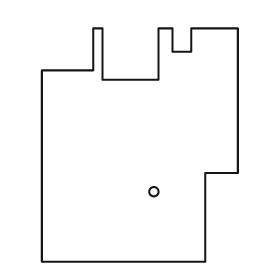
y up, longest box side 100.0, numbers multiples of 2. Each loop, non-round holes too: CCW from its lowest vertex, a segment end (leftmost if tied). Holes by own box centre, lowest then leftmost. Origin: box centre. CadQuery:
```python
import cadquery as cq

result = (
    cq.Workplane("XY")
    .moveTo(-42.0, -50.0)
    .lineTo(28.0, -50.0)
    .lineTo(28.0, -12.0)
    .lineTo(42.0, -12.0)
    .lineTo(42.0, 50.0)
    .lineTo(22.0, 50.0)
    .lineTo(22.0, 40.0)
    .lineTo(14.0, 40.0)
    .lineTo(14.0, 50.0)
    .lineTo(8.0, 50.0)
    .lineTo(8.0, 28.0)
    .lineTo(-16.0, 28.0)
    .lineTo(-16.0, 50.0)
    .lineTo(-20.0, 50.0)
    .lineTo(-20.0, 32.0)
    .lineTo(-42.0, 32.0)
    .close()
    .moveTo(6.0, -20.0)
    .circle(2.0)
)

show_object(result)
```